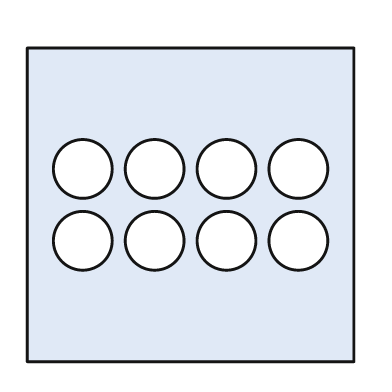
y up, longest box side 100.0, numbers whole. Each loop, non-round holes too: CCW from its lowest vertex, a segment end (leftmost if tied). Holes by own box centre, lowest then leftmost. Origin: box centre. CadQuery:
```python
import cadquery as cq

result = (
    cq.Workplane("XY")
    .moveTo(-50.0, -48.0)
    .lineTo(50.0, -48.0)
    .lineTo(50.0, 48.0)
    .lineTo(-50.0, 48.0)
    .close()
    .moveTo(-33.0, -11.0)
    .circle(9.0)
    .moveTo(-11.0, -11.0)
    .circle(9.0)
    .moveTo(11.0, -11.0)
    .circle(9.0)
    .moveTo(33.0, -11.0)
    .circle(9.0)
    .moveTo(-33.0, 11.0)
    .circle(9.0)
    .moveTo(-11.0, 11.0)
    .circle(9.0)
    .moveTo(11.0, 11.0)
    .circle(9.0)
    .moveTo(33.0, 11.0)
    .circle(9.0)
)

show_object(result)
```